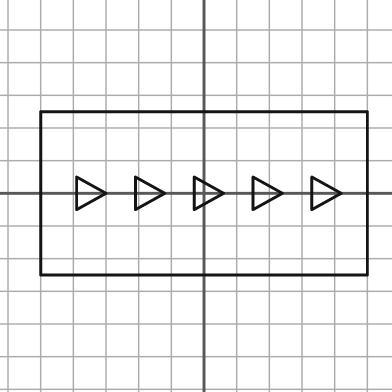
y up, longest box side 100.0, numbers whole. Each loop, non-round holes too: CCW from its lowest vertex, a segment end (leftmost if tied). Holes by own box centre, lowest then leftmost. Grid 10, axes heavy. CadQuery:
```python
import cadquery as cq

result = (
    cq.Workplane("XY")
    .moveTo(-50.0, -25.0)
    .lineTo(50.0, -25.0)
    .lineTo(50.0, 25.0)
    .lineTo(-50.0, 25.0)
    .close()
    .moveTo(-39.0, -5.0)
    .lineTo(-30.0, 0.0)
    .lineTo(-39.0, 5.0)
    .close()
    .moveTo(-21.0, -5.0)
    .lineTo(-12.0, 0.0)
    .lineTo(-21.0, 5.0)
    .close()
    .moveTo(-3.0, -5.0)
    .lineTo(6.0, 0.0)
    .lineTo(-3.0, 5.0)
    .close()
    .moveTo(15.0, -5.0)
    .lineTo(24.0, 0.0)
    .lineTo(15.0, 5.0)
    .close()
    .moveTo(33.0, -5.0)
    .lineTo(42.0, 0.0)
    .lineTo(33.0, 5.0)
    .close()
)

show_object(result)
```